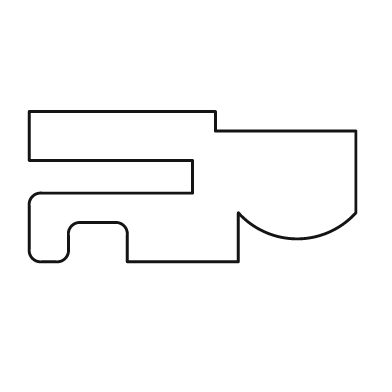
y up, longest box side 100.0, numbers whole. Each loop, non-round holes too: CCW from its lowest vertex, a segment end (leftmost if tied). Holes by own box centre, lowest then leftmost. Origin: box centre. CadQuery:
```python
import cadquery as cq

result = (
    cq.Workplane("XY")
    .moveTo(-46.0, -23.0)
    .lineTo(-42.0, -23.0)
    .threePointArc((-39.0, -22.0), (-38.0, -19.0))
    .lineTo(-38.0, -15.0)
    .threePointArc((-37.0, -12.0), (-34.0, -11.0))
    .lineTo(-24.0, -11.0)
    .threePointArc((-21.0, -12.0), (-20.0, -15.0))
    .lineTo(-20.0, -23.0)
    .lineTo(14.0, -23.0)
    .lineTo(14.0, -8.0)
    .threePointArc((32.0, -16.0), (50.0, -8.0))
    .lineTo(50.0, 17.0)
    .lineTo(7.0, 17.0)
    .lineTo(7.0, 23.0)
    .lineTo(-50.0, 23.0)
    .lineTo(-50.0, 8.0)
    .lineTo(0.0, 8.0)
    .lineTo(0.0, -2.0)
    .lineTo(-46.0, -2.0)
    .threePointArc((-49.0, -3.0), (-50.0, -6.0))
    .lineTo(-50.0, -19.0)
    .threePointArc((-49.0, -22.0), (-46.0, -23.0))
    .close()
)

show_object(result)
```